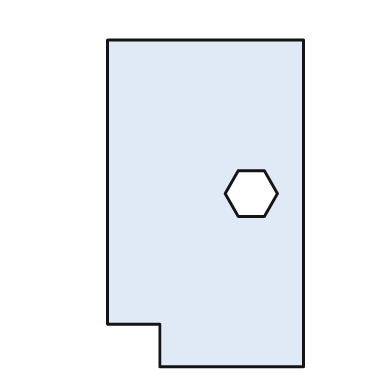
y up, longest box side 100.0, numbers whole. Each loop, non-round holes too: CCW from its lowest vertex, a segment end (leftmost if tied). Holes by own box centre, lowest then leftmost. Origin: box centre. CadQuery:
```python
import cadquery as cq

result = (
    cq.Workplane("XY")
    .moveTo(-14.0, -50.0)
    .lineTo(30.0, -50.0)
    .lineTo(30.0, 50.0)
    .lineTo(-30.0, 50.0)
    .lineTo(-30.0, -37.0)
    .lineTo(-14.0, -37.0)
    .close()
    .moveTo(10.0, -4.0)
    .lineTo(18.0, -4.0)
    .lineTo(22.0, 3.0)
    .lineTo(18.0, 10.0)
    .lineTo(10.0, 10.0)
    .lineTo(6.0, 3.0)
    .close()
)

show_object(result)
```